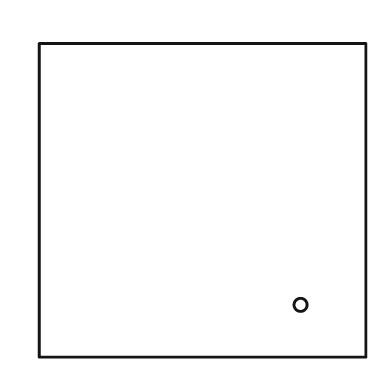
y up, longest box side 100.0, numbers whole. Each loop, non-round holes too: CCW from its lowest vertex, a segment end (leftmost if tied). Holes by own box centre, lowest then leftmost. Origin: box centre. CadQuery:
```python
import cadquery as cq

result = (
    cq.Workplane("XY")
    .moveTo(-50.0, -48.0)
    .lineTo(50.0, -48.0)
    .lineTo(50.0, 48.0)
    .lineTo(-50.0, 48.0)
    .close()
    .moveTo(30.0, -32.0)
    .circle(2.0)
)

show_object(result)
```